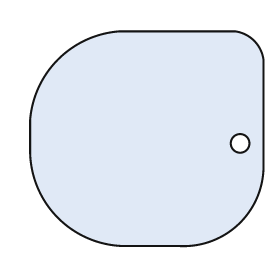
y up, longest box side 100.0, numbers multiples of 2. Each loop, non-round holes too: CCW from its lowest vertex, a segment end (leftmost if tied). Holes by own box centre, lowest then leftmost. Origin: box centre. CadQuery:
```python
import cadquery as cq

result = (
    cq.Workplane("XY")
    .moveTo(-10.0, -46.0)
    .lineTo(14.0, -46.0)
    .threePointArc((40.0, -36.0), (50.0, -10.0))
    .lineTo(50.0, 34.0)
    .threePointArc((46.0, 42.0), (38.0, 46.0))
    .lineTo(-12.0, 46.0)
    .threePointArc((-38.0, 34.0), (-50.0, 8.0))
    .lineTo(-50.0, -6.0)
    .threePointArc((-38.0, -34.0), (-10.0, -46.0))
    .close()
    .moveTo(40.0, -2.0)
    .circle(4.0)
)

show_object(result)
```